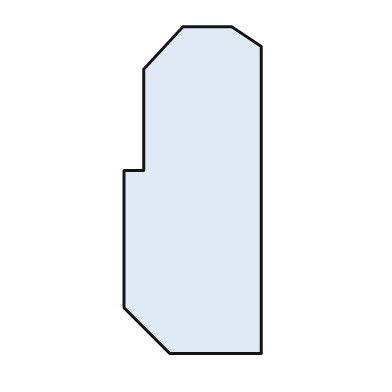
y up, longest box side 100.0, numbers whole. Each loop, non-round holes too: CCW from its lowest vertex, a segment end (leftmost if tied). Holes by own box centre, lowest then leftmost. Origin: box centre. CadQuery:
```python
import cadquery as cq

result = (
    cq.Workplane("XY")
    .moveTo(-7.0, -50.0)
    .lineTo(21.0, -50.0)
    .lineTo(21.0, 44.0)
    .lineTo(12.0, 50.0)
    .lineTo(-3.0, 50.0)
    .lineTo(-15.0, 37.0)
    .lineTo(-15.0, 6.0)
    .lineTo(-21.0, 6.0)
    .lineTo(-21.0, -36.0)
    .close()
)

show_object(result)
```